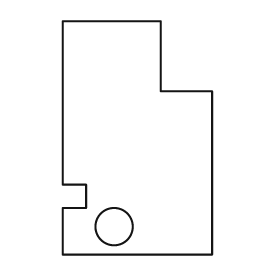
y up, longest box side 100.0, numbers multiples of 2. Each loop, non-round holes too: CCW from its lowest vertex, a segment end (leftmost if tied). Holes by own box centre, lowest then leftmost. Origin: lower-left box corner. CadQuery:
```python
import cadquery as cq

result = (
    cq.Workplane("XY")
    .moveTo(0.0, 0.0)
    .lineTo(64.0, 0.0)
    .lineTo(64.0, 70.0)
    .lineTo(42.0, 70.0)
    .lineTo(42.0, 100.0)
    .lineTo(0.0, 100.0)
    .lineTo(0.0, 30.0)
    .lineTo(10.0, 30.0)
    .lineTo(10.0, 20.0)
    .lineTo(0.0, 20.0)
    .close()
    .moveTo(22.0, 12.0)
    .circle(8.0)
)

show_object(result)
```